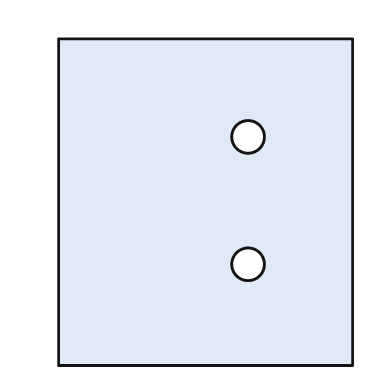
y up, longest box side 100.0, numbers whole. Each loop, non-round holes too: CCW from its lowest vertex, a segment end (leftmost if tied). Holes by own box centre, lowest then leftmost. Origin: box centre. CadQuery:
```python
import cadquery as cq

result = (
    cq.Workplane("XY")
    .moveTo(-45.0, -50.0)
    .lineTo(45.0, -50.0)
    .lineTo(45.0, 50.0)
    .lineTo(-45.0, 50.0)
    .close()
    .moveTo(13.0, -19.0)
    .circle(5.0)
    .moveTo(13.0, 20.0)
    .circle(5.0)
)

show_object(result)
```